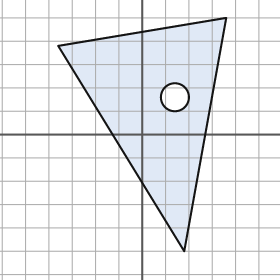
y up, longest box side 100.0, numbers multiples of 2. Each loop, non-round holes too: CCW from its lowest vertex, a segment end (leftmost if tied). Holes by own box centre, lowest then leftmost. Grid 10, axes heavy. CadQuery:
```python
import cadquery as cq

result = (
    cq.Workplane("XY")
    .moveTo(18.0, -50.0)
    .lineTo(36.0, 50.0)
    .lineTo(-36.0, 38.0)
    .close()
    .moveTo(14.0, 16.0)
    .circle(6.0)
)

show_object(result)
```